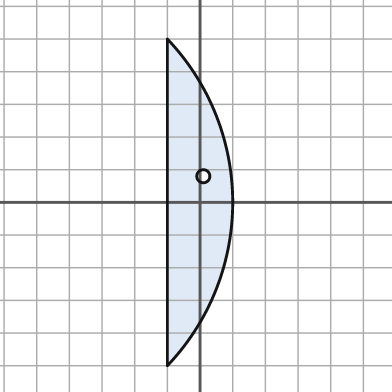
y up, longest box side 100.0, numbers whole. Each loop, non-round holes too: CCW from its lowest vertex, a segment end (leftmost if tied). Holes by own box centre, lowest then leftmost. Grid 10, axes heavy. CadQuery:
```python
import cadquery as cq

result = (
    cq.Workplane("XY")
    .moveTo(-10.0, -50.0)
    .threePointArc((10.0, 0.0), (-10.0, 50.0))
    .close()
    .moveTo(1.0, 8.0)
    .circle(2.0)
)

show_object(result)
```